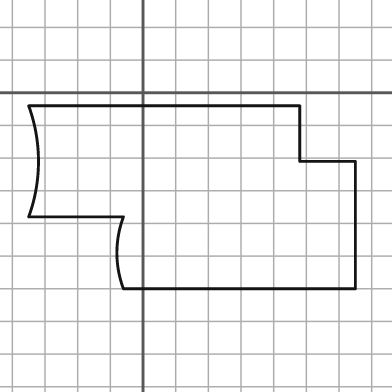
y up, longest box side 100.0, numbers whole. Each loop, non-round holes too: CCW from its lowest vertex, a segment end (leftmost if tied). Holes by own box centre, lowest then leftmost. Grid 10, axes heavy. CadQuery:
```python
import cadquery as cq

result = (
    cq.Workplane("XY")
    .moveTo(-6.0, -60.0)
    .lineTo(65.0, -60.0)
    .lineTo(65.0, -21.0)
    .lineTo(48.0, -21.0)
    .lineTo(48.0, -4.0)
    .lineTo(-35.0, -4.0)
    .threePointArc((-32.0, -21.0), (-35.0, -38.0))
    .lineTo(-6.0, -38.0)
    .threePointArc((-8.0, -49.0), (-6.0, -60.0))
    .close()
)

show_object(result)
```